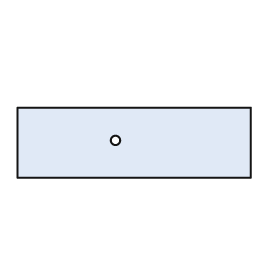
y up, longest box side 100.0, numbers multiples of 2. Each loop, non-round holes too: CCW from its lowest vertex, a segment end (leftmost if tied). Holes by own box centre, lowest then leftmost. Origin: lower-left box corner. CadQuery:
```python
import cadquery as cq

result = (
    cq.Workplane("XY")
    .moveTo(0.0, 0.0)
    .lineTo(100.0, 0.0)
    .lineTo(100.0, 30.0)
    .lineTo(0.0, 30.0)
    .close()
    .moveTo(42.0, 16.0)
    .circle(2.0)
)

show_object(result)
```